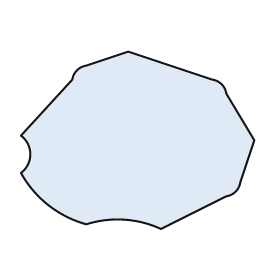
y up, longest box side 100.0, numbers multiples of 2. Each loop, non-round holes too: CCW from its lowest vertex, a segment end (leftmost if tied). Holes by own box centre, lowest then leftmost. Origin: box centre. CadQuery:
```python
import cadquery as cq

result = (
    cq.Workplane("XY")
    .moveTo(10.0, -38.0)
    .lineTo(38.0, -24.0)
    .threePointArc((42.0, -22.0), (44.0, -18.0))
    .lineTo(50.0, 0.0)
    .lineTo(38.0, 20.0)
    .threePointArc((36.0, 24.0), (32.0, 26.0))
    .lineTo(-4.0, 38.0)
    .lineTo(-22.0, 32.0)
    .threePointArc((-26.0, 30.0), (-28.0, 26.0))
    .lineTo(-50.0, 2.0)
    .threePointArc((-46.0, -6.0), (-50.0, -14.0))
    .threePointArc((-38.0, -28.0), (-22.0, -36.0))
    .threePointArc((-6.0, -34.0), (10.0, -38.0))
    .close()
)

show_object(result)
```